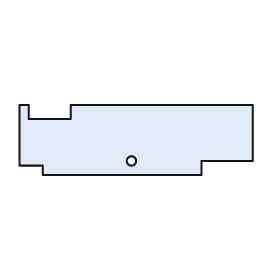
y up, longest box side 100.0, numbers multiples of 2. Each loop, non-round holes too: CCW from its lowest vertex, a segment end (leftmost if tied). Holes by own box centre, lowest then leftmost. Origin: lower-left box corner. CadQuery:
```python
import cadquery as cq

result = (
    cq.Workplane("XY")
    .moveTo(10.0, 0.0)
    .lineTo(78.0, 0.0)
    .lineTo(78.0, 6.0)
    .lineTo(100.0, 6.0)
    .lineTo(100.0, 30.0)
    .lineTo(22.0, 30.0)
    .lineTo(22.0, 24.0)
    .lineTo(4.0, 24.0)
    .lineTo(4.0, 30.0)
    .lineTo(0.0, 30.0)
    .lineTo(0.0, 4.0)
    .lineTo(10.0, 4.0)
    .close()
    .moveTo(48.0, 6.0)
    .circle(2.0)
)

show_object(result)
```